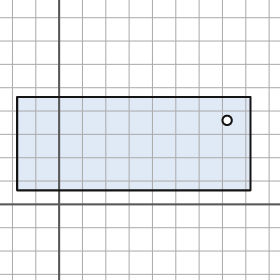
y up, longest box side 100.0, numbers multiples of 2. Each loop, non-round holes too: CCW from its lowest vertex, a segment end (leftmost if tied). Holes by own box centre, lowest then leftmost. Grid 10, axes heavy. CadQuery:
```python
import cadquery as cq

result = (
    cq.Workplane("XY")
    .moveTo(-18.0, 6.0)
    .lineTo(82.0, 6.0)
    .lineTo(82.0, 46.0)
    .lineTo(-18.0, 46.0)
    .close()
    .moveTo(72.0, 36.0)
    .circle(2.0)
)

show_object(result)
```